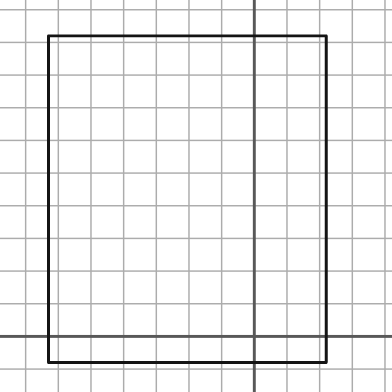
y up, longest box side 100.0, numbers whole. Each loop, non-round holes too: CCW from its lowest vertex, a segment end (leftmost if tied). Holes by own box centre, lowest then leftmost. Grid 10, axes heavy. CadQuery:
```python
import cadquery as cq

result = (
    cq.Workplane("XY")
    .moveTo(-63.0, -8.0)
    .lineTo(22.0, -8.0)
    .lineTo(22.0, 92.0)
    .lineTo(-63.0, 92.0)
    .close()
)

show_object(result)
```